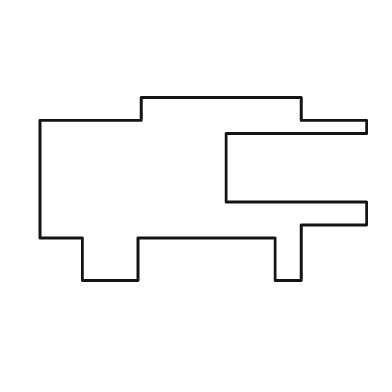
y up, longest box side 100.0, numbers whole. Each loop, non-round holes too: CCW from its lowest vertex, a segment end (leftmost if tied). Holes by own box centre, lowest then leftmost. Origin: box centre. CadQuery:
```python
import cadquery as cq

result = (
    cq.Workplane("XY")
    .moveTo(-37.0, -28.0)
    .lineTo(-20.0, -28.0)
    .lineTo(-20.0, -15.0)
    .lineTo(22.0, -15.0)
    .lineTo(22.0, -28.0)
    .lineTo(30.0, -28.0)
    .lineTo(30.0, -11.0)
    .lineTo(50.0, -11.0)
    .lineTo(50.0, -4.0)
    .lineTo(7.0, -4.0)
    .lineTo(7.0, 17.0)
    .lineTo(50.0, 17.0)
    .lineTo(50.0, 21.0)
    .lineTo(30.0, 21.0)
    .lineTo(30.0, 28.0)
    .lineTo(-19.0, 28.0)
    .lineTo(-19.0, 21.0)
    .lineTo(-50.0, 21.0)
    .lineTo(-50.0, -15.0)
    .lineTo(-37.0, -15.0)
    .close()
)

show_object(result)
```